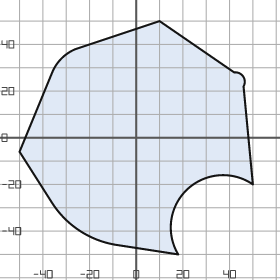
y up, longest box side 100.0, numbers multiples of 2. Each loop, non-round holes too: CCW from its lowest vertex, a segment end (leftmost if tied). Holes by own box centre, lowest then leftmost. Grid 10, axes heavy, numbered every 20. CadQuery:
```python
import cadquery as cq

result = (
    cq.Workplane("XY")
    .moveTo(18.0, -50.0)
    .threePointArc((22.0, -22.0), (50.0, -20.0))
    .lineTo(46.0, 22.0)
    .threePointArc((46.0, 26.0), (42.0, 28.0))
    .lineTo(10.0, 50.0)
    .lineTo(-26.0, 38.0)
    .threePointArc((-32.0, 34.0), (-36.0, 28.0))
    .lineTo(-50.0, -6.0)
    .lineTo(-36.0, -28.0)
    .threePointArc((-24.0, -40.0), (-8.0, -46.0))
    .close()
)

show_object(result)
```